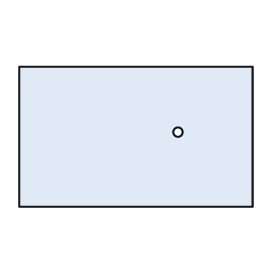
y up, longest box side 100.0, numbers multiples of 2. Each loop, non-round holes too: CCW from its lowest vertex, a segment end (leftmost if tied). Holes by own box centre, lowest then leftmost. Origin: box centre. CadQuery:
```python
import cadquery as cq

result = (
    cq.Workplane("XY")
    .moveTo(-50.0, -30.0)
    .lineTo(50.0, -30.0)
    .lineTo(50.0, 30.0)
    .lineTo(-50.0, 30.0)
    .close()
    .moveTo(18.0, 2.0)
    .circle(2.0)
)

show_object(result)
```